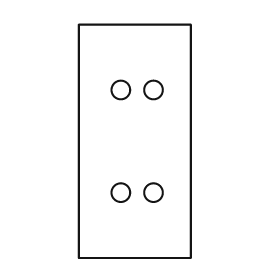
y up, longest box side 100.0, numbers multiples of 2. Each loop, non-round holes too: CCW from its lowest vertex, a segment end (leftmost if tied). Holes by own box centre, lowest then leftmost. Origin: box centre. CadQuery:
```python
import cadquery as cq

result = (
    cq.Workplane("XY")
    .moveTo(-24.0, -50.0)
    .lineTo(24.0, -50.0)
    .lineTo(24.0, 50.0)
    .lineTo(-24.0, 50.0)
    .close()
    .moveTo(-6.0, -22.0)
    .circle(4.0)
    .moveTo(8.0, -22.0)
    .circle(4.0)
    .moveTo(-6.0, 22.0)
    .circle(4.0)
    .moveTo(8.0, 22.0)
    .circle(4.0)
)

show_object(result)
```